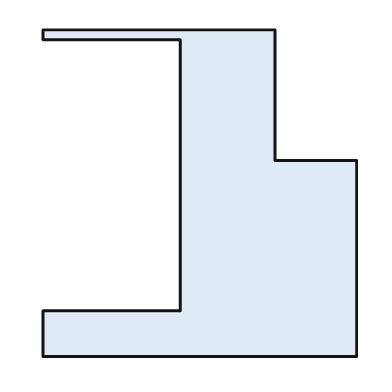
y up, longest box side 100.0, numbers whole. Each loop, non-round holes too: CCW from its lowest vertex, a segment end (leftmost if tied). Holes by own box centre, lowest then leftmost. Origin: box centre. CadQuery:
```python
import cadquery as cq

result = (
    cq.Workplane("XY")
    .moveTo(-48.0, -50.0)
    .lineTo(48.0, -50.0)
    .lineTo(48.0, 10.0)
    .lineTo(23.0, 10.0)
    .lineTo(23.0, 50.0)
    .lineTo(-48.0, 50.0)
    .lineTo(-48.0, 47.0)
    .lineTo(-6.0, 47.0)
    .lineTo(-6.0, -36.0)
    .lineTo(-48.0, -36.0)
    .close()
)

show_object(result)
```